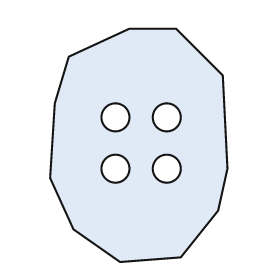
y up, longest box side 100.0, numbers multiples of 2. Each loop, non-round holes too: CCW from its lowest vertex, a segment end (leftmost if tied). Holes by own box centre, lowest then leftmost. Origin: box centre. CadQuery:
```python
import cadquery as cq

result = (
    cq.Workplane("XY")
    .moveTo(-8.0, -50.0)
    .lineTo(18.0, -48.0)
    .lineTo(34.0, -28.0)
    .lineTo(38.0, -10.0)
    .lineTo(36.0, 30.0)
    .lineTo(16.0, 50.0)
    .lineTo(-4.0, 50.0)
    .lineTo(-30.0, 38.0)
    .lineTo(-36.0, 18.0)
    .lineTo(-38.0, -14.0)
    .lineTo(-28.0, -36.0)
    .close()
    .moveTo(-10.0, -10.0)
    .circle(6.0)
    .moveTo(12.0, -10.0)
    .circle(6.0)
    .moveTo(-10.0, 12.0)
    .circle(6.0)
    .moveTo(12.0, 12.0)
    .circle(6.0)
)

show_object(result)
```